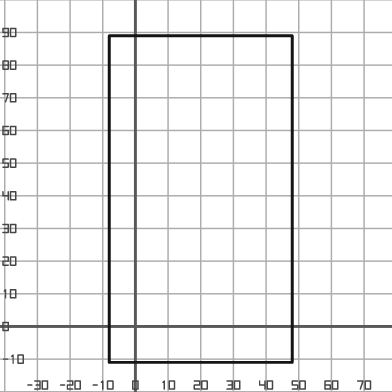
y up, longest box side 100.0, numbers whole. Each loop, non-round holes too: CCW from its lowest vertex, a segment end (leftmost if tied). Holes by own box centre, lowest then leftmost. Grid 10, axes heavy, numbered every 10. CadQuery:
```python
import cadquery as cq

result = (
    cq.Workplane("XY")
    .moveTo(-8.0, -11.0)
    .lineTo(48.0, -11.0)
    .lineTo(48.0, 89.0)
    .lineTo(-8.0, 89.0)
    .close()
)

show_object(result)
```